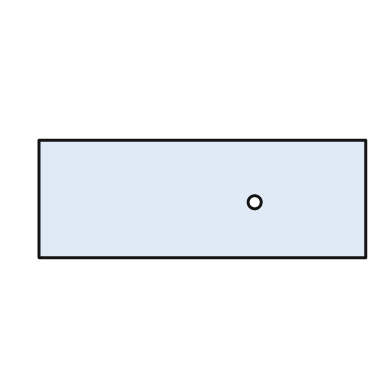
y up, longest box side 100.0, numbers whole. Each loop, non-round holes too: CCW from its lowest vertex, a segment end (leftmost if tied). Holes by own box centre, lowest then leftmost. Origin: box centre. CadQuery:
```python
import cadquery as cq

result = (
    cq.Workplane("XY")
    .moveTo(-50.0, -18.0)
    .lineTo(50.0, -18.0)
    .lineTo(50.0, 18.0)
    .lineTo(-50.0, 18.0)
    .close()
    .moveTo(16.0, -1.0)
    .circle(2.0)
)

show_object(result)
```